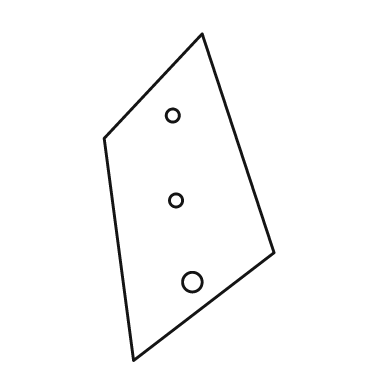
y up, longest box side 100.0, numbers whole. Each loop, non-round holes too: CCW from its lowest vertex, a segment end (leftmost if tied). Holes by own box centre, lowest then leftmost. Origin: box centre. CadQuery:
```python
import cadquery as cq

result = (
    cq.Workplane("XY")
    .moveTo(-17.0, -50.0)
    .lineTo(26.0, -17.0)
    .lineTo(4.0, 50.0)
    .lineTo(-26.0, 18.0)
    .close()
    .moveTo(1.0, -26.0)
    .circle(3.0)
    .moveTo(-4.0, -1.0)
    .circle(2.0)
    .moveTo(-5.0, 25.0)
    .circle(2.0)
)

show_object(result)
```